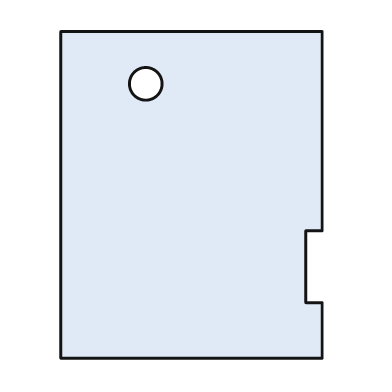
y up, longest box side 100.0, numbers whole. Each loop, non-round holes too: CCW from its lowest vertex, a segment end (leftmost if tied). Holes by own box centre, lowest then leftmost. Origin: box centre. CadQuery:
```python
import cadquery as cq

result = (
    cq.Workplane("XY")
    .moveTo(-40.0, -50.0)
    .lineTo(40.0, -50.0)
    .lineTo(40.0, -33.0)
    .lineTo(35.0, -33.0)
    .lineTo(35.0, -11.0)
    .lineTo(40.0, -11.0)
    .lineTo(40.0, 50.0)
    .lineTo(-40.0, 50.0)
    .close()
    .moveTo(-14.0, 34.0)
    .circle(5.0)
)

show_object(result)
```